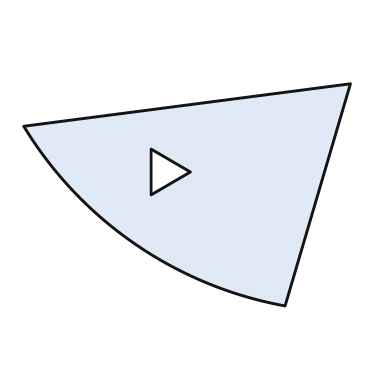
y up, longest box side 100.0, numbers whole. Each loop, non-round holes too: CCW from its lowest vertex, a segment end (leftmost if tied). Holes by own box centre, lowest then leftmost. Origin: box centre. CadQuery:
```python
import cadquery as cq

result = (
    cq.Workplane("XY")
    .moveTo(30.0, -34.0)
    .lineTo(50.0, 34.0)
    .lineTo(-50.0, 21.0)
    .threePointArc((-16.0, -15.0), (30.0, -34.0))
    .close()
    .moveTo(-11.0, 0.0)
    .lineTo(1.0, 7.0)
    .lineTo(-11.0, 14.0)
    .close()
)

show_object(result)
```